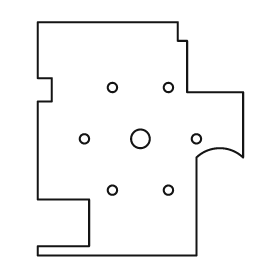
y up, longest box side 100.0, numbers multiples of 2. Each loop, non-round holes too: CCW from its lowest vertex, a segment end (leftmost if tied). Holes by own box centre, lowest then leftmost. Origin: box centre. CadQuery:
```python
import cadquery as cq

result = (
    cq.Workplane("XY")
    .moveTo(-44.0, -50.0)
    .lineTo(24.0, -50.0)
    .lineTo(24.0, -8.0)
    .threePointArc((34.0, -4.0), (44.0, -8.0))
    .lineTo(44.0, 20.0)
    .lineTo(20.0, 20.0)
    .lineTo(20.0, 42.0)
    .lineTo(16.0, 42.0)
    .lineTo(16.0, 50.0)
    .lineTo(-44.0, 50.0)
    .lineTo(-44.0, 26.0)
    .lineTo(-38.0, 26.0)
    .lineTo(-38.0, 16.0)
    .lineTo(-44.0, 16.0)
    .lineTo(-44.0, -26.0)
    .lineTo(-22.0, -26.0)
    .lineTo(-22.0, -46.0)
    .lineTo(-44.0, -46.0)
    .close()
    .moveTo(-12.0, -22.0)
    .circle(2.0)
    .moveTo(12.0, -22.0)
    .circle(2.0)
    .moveTo(-24.0, 0.0)
    .circle(2.0)
    .moveTo(0.0, 0.0)
    .circle(4.0)
    .moveTo(24.0, 0.0)
    .circle(2.0)
    .moveTo(-12.0, 22.0)
    .circle(2.0)
    .moveTo(12.0, 22.0)
    .circle(2.0)
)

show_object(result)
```